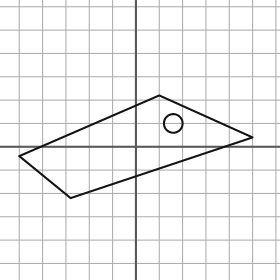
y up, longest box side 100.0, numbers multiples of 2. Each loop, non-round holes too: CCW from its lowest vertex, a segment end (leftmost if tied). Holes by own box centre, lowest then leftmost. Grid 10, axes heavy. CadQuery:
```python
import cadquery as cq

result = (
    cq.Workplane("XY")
    .moveTo(-28.0, -22.0)
    .lineTo(50.0, 4.0)
    .lineTo(10.0, 22.0)
    .lineTo(-50.0, -4.0)
    .close()
    .moveTo(16.0, 10.0)
    .circle(4.0)
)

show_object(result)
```